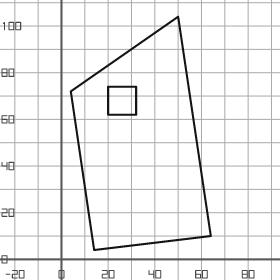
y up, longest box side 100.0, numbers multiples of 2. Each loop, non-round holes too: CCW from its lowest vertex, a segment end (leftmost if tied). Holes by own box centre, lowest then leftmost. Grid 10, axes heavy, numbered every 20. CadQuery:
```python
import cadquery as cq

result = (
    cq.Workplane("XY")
    .moveTo(14.0, 4.0)
    .lineTo(64.0, 10.0)
    .lineTo(50.0, 104.0)
    .lineTo(4.0, 72.0)
    .close()
    .moveTo(20.0, 62.0)
    .lineTo(32.0, 62.0)
    .lineTo(32.0, 74.0)
    .lineTo(20.0, 74.0)
    .close()
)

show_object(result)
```